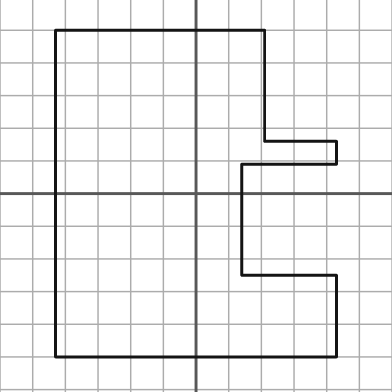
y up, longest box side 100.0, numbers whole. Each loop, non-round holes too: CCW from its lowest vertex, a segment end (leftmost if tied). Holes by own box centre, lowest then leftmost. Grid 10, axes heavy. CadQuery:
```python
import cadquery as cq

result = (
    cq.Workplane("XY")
    .moveTo(-43.0, -50.0)
    .lineTo(43.0, -50.0)
    .lineTo(43.0, -25.0)
    .lineTo(14.0, -25.0)
    .lineTo(14.0, 9.0)
    .lineTo(43.0, 9.0)
    .lineTo(43.0, 16.0)
    .lineTo(21.0, 16.0)
    .lineTo(21.0, 50.0)
    .lineTo(-43.0, 50.0)
    .close()
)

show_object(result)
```